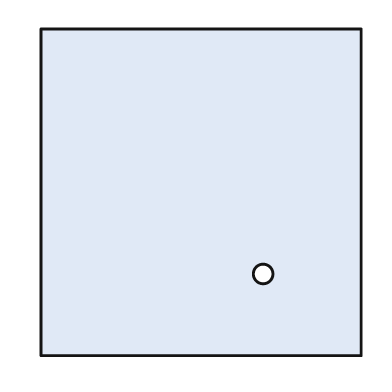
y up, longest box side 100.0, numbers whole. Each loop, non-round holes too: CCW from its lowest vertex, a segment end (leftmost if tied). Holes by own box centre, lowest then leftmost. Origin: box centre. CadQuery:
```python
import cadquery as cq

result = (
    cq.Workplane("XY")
    .moveTo(-49.0, -50.0)
    .lineTo(49.0, -50.0)
    .lineTo(49.0, 50.0)
    .lineTo(-49.0, 50.0)
    .close()
    .moveTo(19.0, -25.0)
    .circle(3.0)
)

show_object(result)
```